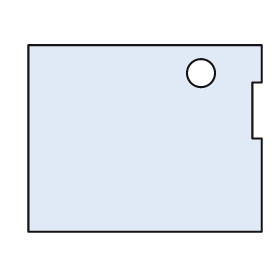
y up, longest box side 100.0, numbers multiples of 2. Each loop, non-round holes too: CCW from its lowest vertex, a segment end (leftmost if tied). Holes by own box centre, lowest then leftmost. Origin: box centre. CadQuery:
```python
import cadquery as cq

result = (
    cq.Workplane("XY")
    .moveTo(-50.0, -40.0)
    .lineTo(50.0, -40.0)
    .lineTo(50.0, 0.0)
    .lineTo(46.0, 0.0)
    .lineTo(46.0, 24.0)
    .lineTo(50.0, 24.0)
    .lineTo(50.0, 40.0)
    .lineTo(-50.0, 40.0)
    .close()
    .moveTo(24.0, 28.0)
    .circle(6.0)
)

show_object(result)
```